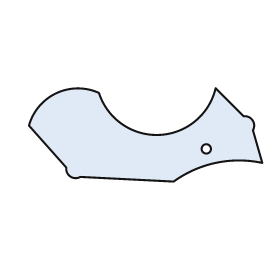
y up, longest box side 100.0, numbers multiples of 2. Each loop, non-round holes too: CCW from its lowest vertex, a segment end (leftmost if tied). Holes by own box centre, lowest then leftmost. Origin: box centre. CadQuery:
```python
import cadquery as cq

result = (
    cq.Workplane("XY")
    .moveTo(12.0, -20.0)
    .threePointArc((30.0, -12.0), (50.0, -12.0))
    .lineTo(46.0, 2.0)
    .threePointArc((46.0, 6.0), (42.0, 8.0))
    .lineTo(30.0, 20.0)
    .threePointArc((6.0, 0.0), (-20.0, 18.0))
    .threePointArc((-38.0, 18.0), (-50.0, 4.0))
    .lineTo(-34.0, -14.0)
    .threePointArc((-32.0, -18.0), (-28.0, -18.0))
    .close()
    .moveTo(26.0, -6.0)
    .circle(2.0)
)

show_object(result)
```